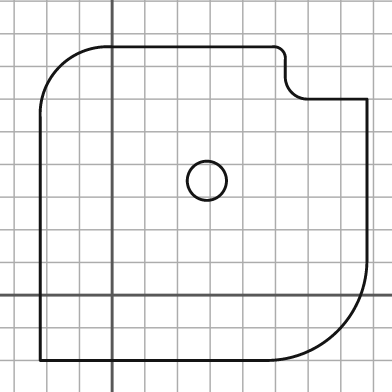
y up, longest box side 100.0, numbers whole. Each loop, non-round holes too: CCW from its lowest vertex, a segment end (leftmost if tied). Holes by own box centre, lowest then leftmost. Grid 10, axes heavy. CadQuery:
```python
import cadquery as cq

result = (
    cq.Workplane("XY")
    .moveTo(-22.0, -20.0)
    .lineTo(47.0, -20.0)
    .threePointArc((69.0, -11.0), (78.0, 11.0))
    .lineTo(78.0, 60.0)
    .lineTo(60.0, 60.0)
    .threePointArc((55.0, 62.0), (53.0, 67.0))
    .lineTo(53.0, 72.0)
    .threePointArc((52.0, 75.0), (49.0, 76.0))
    .lineTo(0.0, 76.0)
    .threePointArc((-16.0, 70.0), (-22.0, 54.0))
    .close()
    .moveTo(29.0, 35.0)
    .circle(6.0)
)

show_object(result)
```